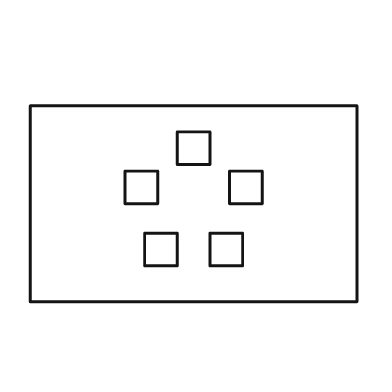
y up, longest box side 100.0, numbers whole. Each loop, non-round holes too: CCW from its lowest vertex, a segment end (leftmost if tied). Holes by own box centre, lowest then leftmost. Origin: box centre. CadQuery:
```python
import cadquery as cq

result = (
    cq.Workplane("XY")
    .moveTo(-50.0, -30.0)
    .lineTo(50.0, -30.0)
    .lineTo(50.0, 30.0)
    .lineTo(-50.0, 30.0)
    .close()
    .moveTo(-15.0, -19.0)
    .lineTo(-5.0, -19.0)
    .lineTo(-5.0, -9.0)
    .lineTo(-15.0, -9.0)
    .close()
    .moveTo(5.0, -19.0)
    .lineTo(15.0, -19.0)
    .lineTo(15.0, -9.0)
    .lineTo(5.0, -9.0)
    .close()
    .moveTo(-21.0, 0.0)
    .lineTo(-11.0, 0.0)
    .lineTo(-11.0, 10.0)
    .lineTo(-21.0, 10.0)
    .close()
    .moveTo(11.0, 0.0)
    .lineTo(21.0, 0.0)
    .lineTo(21.0, 10.0)
    .lineTo(11.0, 10.0)
    .close()
    .moveTo(-5.0, 12.0)
    .lineTo(5.0, 12.0)
    .lineTo(5.0, 22.0)
    .lineTo(-5.0, 22.0)
    .close()
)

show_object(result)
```